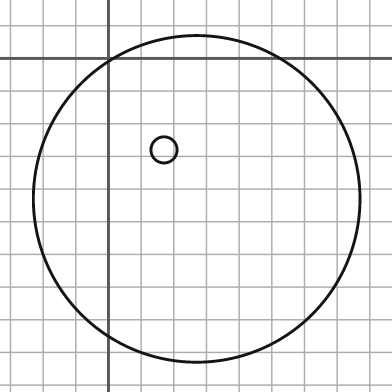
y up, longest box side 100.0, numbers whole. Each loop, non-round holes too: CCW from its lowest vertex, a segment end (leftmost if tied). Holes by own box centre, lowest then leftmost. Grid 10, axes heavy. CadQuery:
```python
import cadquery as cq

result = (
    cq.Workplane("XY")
    .moveTo(27.0, -43.0)
    .circle(50.0)
    .moveTo(17.0, -28.0)
    .circle(4.0)
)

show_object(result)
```